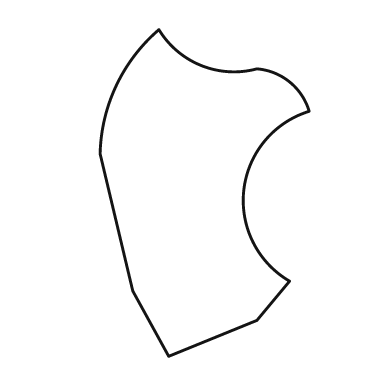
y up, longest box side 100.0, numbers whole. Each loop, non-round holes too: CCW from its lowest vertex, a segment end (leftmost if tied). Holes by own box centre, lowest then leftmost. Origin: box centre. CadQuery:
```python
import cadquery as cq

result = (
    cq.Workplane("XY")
    .moveTo(-11.0, -50.0)
    .lineTo(16.0, -39.0)
    .lineTo(26.0, -27.0)
    .threePointArc((12.0, 1.0), (32.0, 25.0))
    .threePointArc((26.0, 34.0), (16.0, 38.0))
    .threePointArc((-1.0, 39.0), (-14.0, 50.0))
    .threePointArc((-27.0, 33.0), (-32.0, 12.0))
    .lineTo(-22.0, -30.0)
    .close()
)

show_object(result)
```